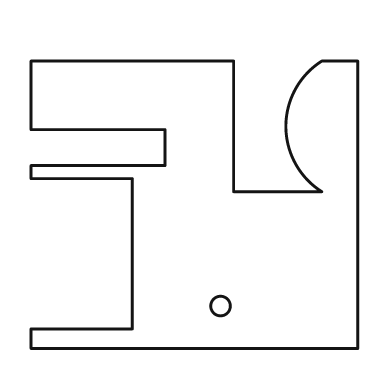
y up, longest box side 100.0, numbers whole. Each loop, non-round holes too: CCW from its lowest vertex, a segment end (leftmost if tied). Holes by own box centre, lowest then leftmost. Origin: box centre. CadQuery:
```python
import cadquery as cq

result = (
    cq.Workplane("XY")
    .moveTo(-50.0, -44.0)
    .lineTo(50.0, -44.0)
    .lineTo(50.0, 44.0)
    .lineTo(39.0, 44.0)
    .threePointArc((28.0, 24.0), (39.0, 4.0))
    .lineTo(12.0, 4.0)
    .lineTo(12.0, 44.0)
    .lineTo(-50.0, 44.0)
    .lineTo(-50.0, 23.0)
    .lineTo(-9.0, 23.0)
    .lineTo(-9.0, 12.0)
    .lineTo(-50.0, 12.0)
    .lineTo(-50.0, 8.0)
    .lineTo(-19.0, 8.0)
    .lineTo(-19.0, -38.0)
    .lineTo(-50.0, -38.0)
    .close()
    .moveTo(8.0, -31.0)
    .circle(3.0)
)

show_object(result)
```